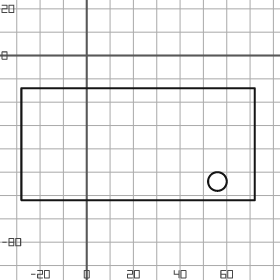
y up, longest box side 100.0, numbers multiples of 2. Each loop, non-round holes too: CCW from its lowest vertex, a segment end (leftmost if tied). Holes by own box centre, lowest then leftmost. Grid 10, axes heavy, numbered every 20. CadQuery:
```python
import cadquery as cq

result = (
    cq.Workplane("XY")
    .moveTo(-28.0, -62.0)
    .lineTo(72.0, -62.0)
    .lineTo(72.0, -14.0)
    .lineTo(-28.0, -14.0)
    .close()
    .moveTo(56.0, -54.0)
    .circle(4.0)
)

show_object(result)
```